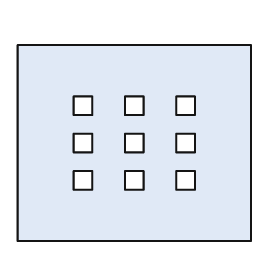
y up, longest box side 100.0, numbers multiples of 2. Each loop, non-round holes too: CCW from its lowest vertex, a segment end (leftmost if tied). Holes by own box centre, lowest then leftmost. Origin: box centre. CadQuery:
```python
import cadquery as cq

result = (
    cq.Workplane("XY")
    .moveTo(-50.0, -42.0)
    .lineTo(50.0, -42.0)
    .lineTo(50.0, 42.0)
    .lineTo(-50.0, 42.0)
    .close()
    .moveTo(-26.0, -20.0)
    .lineTo(-18.0, -20.0)
    .lineTo(-18.0, -12.0)
    .lineTo(-26.0, -12.0)
    .close()
    .moveTo(-4.0, -20.0)
    .lineTo(4.0, -20.0)
    .lineTo(4.0, -12.0)
    .lineTo(-4.0, -12.0)
    .close()
    .moveTo(18.0, -20.0)
    .lineTo(26.0, -20.0)
    .lineTo(26.0, -12.0)
    .lineTo(18.0, -12.0)
    .close()
    .moveTo(-26.0, -4.0)
    .lineTo(-18.0, -4.0)
    .lineTo(-18.0, 4.0)
    .lineTo(-26.0, 4.0)
    .close()
    .moveTo(-4.0, -4.0)
    .lineTo(4.0, -4.0)
    .lineTo(4.0, 4.0)
    .lineTo(-4.0, 4.0)
    .close()
    .moveTo(18.0, -4.0)
    .lineTo(26.0, -4.0)
    .lineTo(26.0, 4.0)
    .lineTo(18.0, 4.0)
    .close()
    .moveTo(-26.0, 12.0)
    .lineTo(-18.0, 12.0)
    .lineTo(-18.0, 20.0)
    .lineTo(-26.0, 20.0)
    .close()
    .moveTo(-4.0, 12.0)
    .lineTo(4.0, 12.0)
    .lineTo(4.0, 20.0)
    .lineTo(-4.0, 20.0)
    .close()
    .moveTo(18.0, 12.0)
    .lineTo(26.0, 12.0)
    .lineTo(26.0, 20.0)
    .lineTo(18.0, 20.0)
    .close()
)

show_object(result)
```